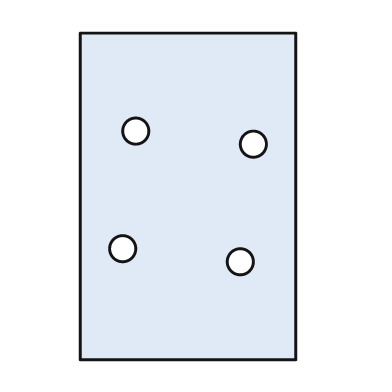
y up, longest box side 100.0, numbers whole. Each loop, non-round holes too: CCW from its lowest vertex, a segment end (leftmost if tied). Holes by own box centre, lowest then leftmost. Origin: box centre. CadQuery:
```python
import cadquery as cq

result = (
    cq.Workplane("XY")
    .moveTo(-33.0, -50.0)
    .lineTo(33.0, -50.0)
    .lineTo(33.0, 50.0)
    .lineTo(-33.0, 50.0)
    .close()
    .moveTo(16.0, -20.0)
    .circle(4.0)
    .moveTo(-20.0, -16.0)
    .circle(4.0)
    .moveTo(20.0, 16.0)
    .circle(4.0)
    .moveTo(-16.0, 20.0)
    .circle(4.0)
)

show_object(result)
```